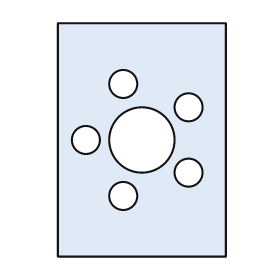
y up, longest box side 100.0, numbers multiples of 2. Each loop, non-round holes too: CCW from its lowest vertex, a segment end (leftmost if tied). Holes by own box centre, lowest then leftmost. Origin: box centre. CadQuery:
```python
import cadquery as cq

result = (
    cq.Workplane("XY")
    .moveTo(-36.0, -50.0)
    .lineTo(36.0, -50.0)
    .lineTo(36.0, 50.0)
    .lineTo(-36.0, 50.0)
    .close()
    .moveTo(-8.0, -24.0)
    .circle(6.0)
    .moveTo(20.0, -14.0)
    .circle(6.0)
    .moveTo(-24.0, 0.0)
    .circle(6.0)
    .moveTo(0.0, 0.0)
    .circle(14.0)
    .moveTo(20.0, 14.0)
    .circle(6.0)
    .moveTo(-8.0, 24.0)
    .circle(6.0)
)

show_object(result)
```